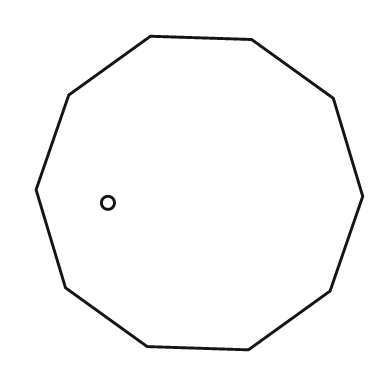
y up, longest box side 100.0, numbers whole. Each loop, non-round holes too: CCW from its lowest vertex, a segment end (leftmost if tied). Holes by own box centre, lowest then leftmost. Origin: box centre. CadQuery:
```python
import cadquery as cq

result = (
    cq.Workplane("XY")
    .moveTo(15.0, -48.0)
    .lineTo(40.0, -30.0)
    .lineTo(50.0, -1.0)
    .lineTo(41.0, 29.0)
    .lineTo(16.0, 47.0)
    .lineTo(-15.0, 48.0)
    .lineTo(-40.0, 30.0)
    .lineTo(-50.0, 1.0)
    .lineTo(-41.0, -29.0)
    .lineTo(-16.0, -47.0)
    .close()
    .moveTo(-28.0, -3.0)
    .circle(2.0)
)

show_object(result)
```